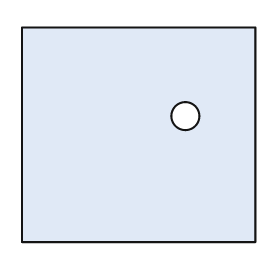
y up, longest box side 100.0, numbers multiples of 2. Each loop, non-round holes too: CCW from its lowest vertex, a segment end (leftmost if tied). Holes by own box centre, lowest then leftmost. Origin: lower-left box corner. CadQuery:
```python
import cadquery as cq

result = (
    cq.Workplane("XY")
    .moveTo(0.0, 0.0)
    .lineTo(100.0, 0.0)
    .lineTo(100.0, 92.0)
    .lineTo(0.0, 92.0)
    .close()
    .moveTo(70.0, 54.0)
    .circle(6.0)
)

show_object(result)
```